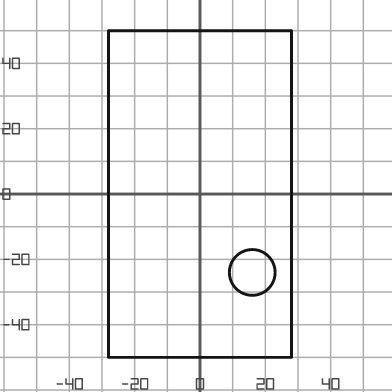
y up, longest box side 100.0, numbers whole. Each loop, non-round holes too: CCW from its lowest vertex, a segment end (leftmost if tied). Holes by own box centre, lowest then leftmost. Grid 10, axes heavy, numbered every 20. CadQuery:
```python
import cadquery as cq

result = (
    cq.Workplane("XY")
    .moveTo(-28.0, -50.0)
    .lineTo(28.0, -50.0)
    .lineTo(28.0, 50.0)
    .lineTo(-28.0, 50.0)
    .close()
    .moveTo(16.0, -24.0)
    .circle(7.0)
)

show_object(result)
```